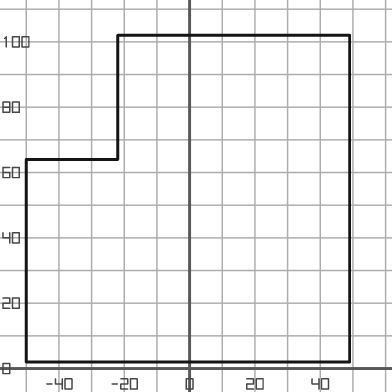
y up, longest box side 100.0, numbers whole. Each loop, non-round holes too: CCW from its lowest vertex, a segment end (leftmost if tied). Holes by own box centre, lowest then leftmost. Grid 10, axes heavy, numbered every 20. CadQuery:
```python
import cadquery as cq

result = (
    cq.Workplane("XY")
    .moveTo(-50.0, 2.0)
    .lineTo(49.0, 2.0)
    .lineTo(49.0, 102.0)
    .lineTo(-22.0, 102.0)
    .lineTo(-22.0, 64.0)
    .lineTo(-50.0, 64.0)
    .close()
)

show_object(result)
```